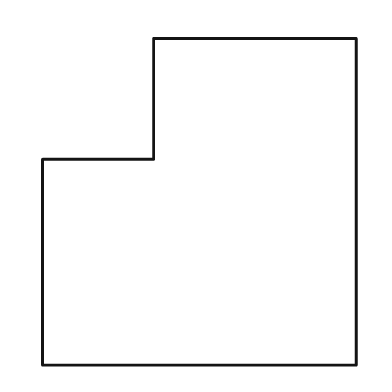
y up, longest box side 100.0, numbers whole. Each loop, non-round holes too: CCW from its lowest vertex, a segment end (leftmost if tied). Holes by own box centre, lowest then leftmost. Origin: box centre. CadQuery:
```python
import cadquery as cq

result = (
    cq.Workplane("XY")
    .moveTo(-48.0, -50.0)
    .lineTo(48.0, -50.0)
    .lineTo(48.0, 50.0)
    .lineTo(-14.0, 50.0)
    .lineTo(-14.0, 13.0)
    .lineTo(-48.0, 13.0)
    .close()
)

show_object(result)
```